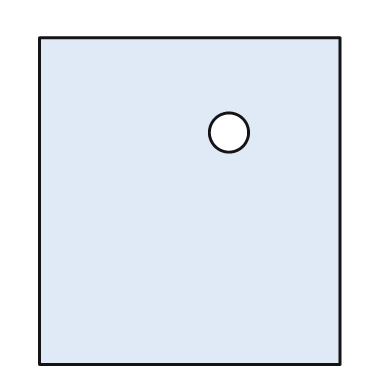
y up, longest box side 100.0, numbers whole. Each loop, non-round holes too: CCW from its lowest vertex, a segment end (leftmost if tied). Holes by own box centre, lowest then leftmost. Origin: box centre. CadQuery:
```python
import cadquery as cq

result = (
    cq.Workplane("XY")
    .moveTo(-46.0, -50.0)
    .lineTo(46.0, -50.0)
    .lineTo(46.0, 50.0)
    .lineTo(-46.0, 50.0)
    .close()
    .moveTo(12.0, 21.0)
    .circle(6.0)
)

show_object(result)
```